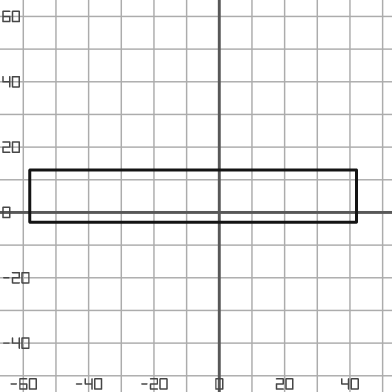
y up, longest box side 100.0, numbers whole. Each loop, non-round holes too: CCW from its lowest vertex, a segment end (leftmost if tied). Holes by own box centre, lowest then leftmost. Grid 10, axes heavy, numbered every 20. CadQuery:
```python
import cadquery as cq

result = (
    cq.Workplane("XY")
    .moveTo(-58.0, -3.0)
    .lineTo(42.0, -3.0)
    .lineTo(42.0, 13.0)
    .lineTo(-58.0, 13.0)
    .close()
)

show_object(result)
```